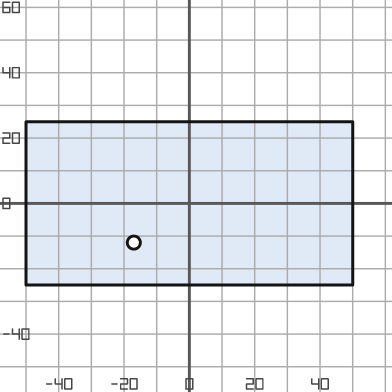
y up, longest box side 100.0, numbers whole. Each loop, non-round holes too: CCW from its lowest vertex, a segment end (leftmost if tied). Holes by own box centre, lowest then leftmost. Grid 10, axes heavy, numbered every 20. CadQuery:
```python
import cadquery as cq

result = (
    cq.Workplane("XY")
    .moveTo(-50.0, -25.0)
    .lineTo(50.0, -25.0)
    .lineTo(50.0, 25.0)
    .lineTo(-50.0, 25.0)
    .close()
    .moveTo(-17.0, -12.0)
    .circle(2.0)
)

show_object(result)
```